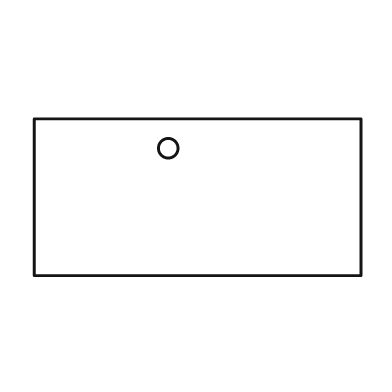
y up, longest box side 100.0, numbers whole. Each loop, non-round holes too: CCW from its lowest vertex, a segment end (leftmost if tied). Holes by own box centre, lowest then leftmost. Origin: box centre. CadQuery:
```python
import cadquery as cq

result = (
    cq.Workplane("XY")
    .moveTo(-50.0, -24.0)
    .lineTo(50.0, -24.0)
    .lineTo(50.0, 24.0)
    .lineTo(-50.0, 24.0)
    .close()
    .moveTo(-9.0, 15.0)
    .circle(3.0)
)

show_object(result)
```